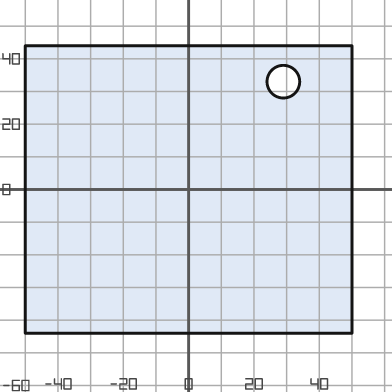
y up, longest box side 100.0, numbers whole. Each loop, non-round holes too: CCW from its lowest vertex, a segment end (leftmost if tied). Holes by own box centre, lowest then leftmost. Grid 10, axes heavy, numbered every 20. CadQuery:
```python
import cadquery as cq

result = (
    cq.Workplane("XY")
    .moveTo(-50.0, -44.0)
    .lineTo(50.0, -44.0)
    .lineTo(50.0, 44.0)
    .lineTo(-50.0, 44.0)
    .close()
    .moveTo(29.0, 33.0)
    .circle(5.0)
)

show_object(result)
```